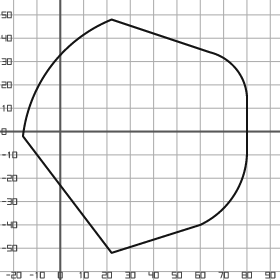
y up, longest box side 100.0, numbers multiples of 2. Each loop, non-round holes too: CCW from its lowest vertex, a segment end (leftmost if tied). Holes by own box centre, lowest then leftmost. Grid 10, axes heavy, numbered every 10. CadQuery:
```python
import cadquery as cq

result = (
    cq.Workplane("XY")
    .moveTo(22.0, -52.0)
    .lineTo(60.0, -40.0)
    .threePointArc((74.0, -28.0), (80.0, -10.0))
    .lineTo(80.0, 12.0)
    .threePointArc((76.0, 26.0), (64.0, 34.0))
    .lineTo(22.0, 48.0)
    .threePointArc((-4.0, 28.0), (-16.0, -2.0))
    .close()
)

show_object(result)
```